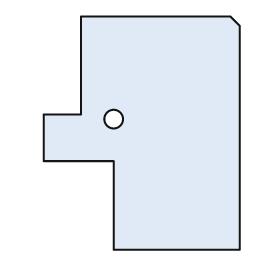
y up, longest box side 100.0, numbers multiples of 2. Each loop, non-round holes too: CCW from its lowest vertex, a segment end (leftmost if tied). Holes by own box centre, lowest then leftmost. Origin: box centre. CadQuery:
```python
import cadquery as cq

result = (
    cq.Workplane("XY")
    .moveTo(-12.0, -50.0)
    .lineTo(42.0, -50.0)
    .lineTo(42.0, 46.0)
    .lineTo(38.0, 50.0)
    .lineTo(-26.0, 50.0)
    .lineTo(-26.0, 8.0)
    .lineTo(-42.0, 8.0)
    .lineTo(-42.0, -12.0)
    .lineTo(-12.0, -12.0)
    .close()
    .moveTo(-12.0, 6.0)
    .circle(4.0)
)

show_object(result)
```